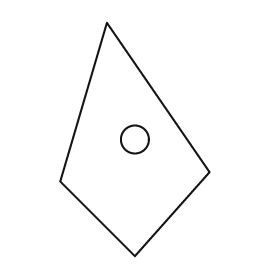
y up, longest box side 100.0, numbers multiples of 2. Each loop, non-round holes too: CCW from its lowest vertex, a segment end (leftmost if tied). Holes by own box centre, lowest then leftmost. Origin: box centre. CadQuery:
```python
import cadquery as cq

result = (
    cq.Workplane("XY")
    .moveTo(0.0, -50.0)
    .lineTo(32.0, -14.0)
    .lineTo(-12.0, 50.0)
    .lineTo(-32.0, -18.0)
    .close()
    .moveTo(0.0, 0.0)
    .circle(6.0)
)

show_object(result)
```